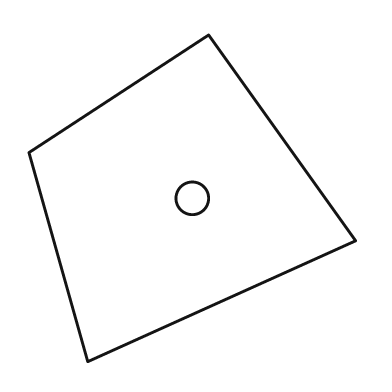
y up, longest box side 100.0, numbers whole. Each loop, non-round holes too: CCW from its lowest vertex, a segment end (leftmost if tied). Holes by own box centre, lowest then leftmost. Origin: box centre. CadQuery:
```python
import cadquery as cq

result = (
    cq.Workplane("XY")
    .moveTo(-32.0, -50.0)
    .lineTo(50.0, -13.0)
    .lineTo(5.0, 50.0)
    .lineTo(-50.0, 14.0)
    .close()
    .moveTo(0.0, 0.0)
    .circle(5.0)
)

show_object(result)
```